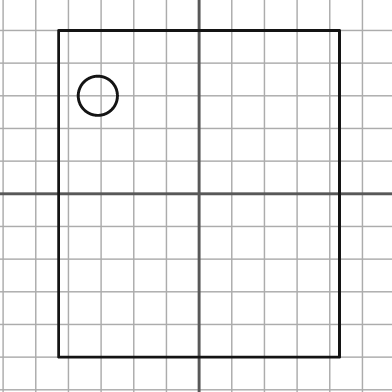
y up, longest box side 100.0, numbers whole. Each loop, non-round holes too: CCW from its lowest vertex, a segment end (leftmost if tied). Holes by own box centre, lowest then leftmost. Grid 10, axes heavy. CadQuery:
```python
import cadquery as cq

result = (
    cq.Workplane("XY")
    .moveTo(-43.0, -50.0)
    .lineTo(43.0, -50.0)
    .lineTo(43.0, 50.0)
    .lineTo(-43.0, 50.0)
    .close()
    .moveTo(-31.0, 30.0)
    .circle(6.0)
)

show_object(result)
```